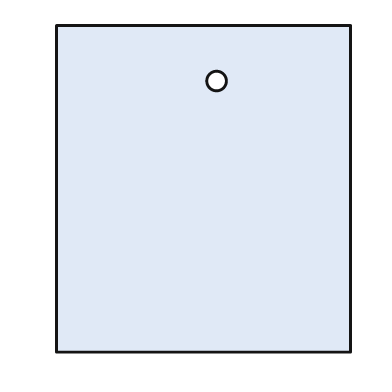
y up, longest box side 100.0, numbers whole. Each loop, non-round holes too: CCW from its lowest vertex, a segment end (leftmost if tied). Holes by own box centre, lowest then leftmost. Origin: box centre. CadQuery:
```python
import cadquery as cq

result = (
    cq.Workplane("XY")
    .moveTo(-45.0, -50.0)
    .lineTo(45.0, -50.0)
    .lineTo(45.0, 50.0)
    .lineTo(-45.0, 50.0)
    .close()
    .moveTo(4.0, 33.0)
    .circle(3.0)
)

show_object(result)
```